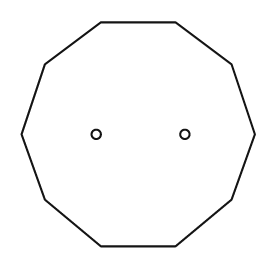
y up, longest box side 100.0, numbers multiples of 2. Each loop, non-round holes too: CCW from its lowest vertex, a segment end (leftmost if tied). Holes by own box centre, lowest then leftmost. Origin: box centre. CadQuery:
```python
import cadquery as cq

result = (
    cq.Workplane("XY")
    .moveTo(-16.0, -48.0)
    .lineTo(16.0, -48.0)
    .lineTo(40.0, -28.0)
    .lineTo(50.0, 0.0)
    .lineTo(40.0, 30.0)
    .lineTo(16.0, 48.0)
    .lineTo(-16.0, 48.0)
    .lineTo(-40.0, 30.0)
    .lineTo(-50.0, 0.0)
    .lineTo(-40.0, -28.0)
    .close()
    .moveTo(-18.0, 0.0)
    .circle(2.0)
    .moveTo(20.0, 0.0)
    .circle(2.0)
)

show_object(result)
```